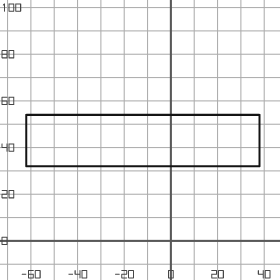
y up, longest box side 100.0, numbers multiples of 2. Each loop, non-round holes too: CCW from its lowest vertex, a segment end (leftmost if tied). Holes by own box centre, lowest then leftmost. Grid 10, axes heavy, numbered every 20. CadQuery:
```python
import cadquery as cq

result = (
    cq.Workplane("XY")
    .moveTo(-62.0, 32.0)
    .lineTo(38.0, 32.0)
    .lineTo(38.0, 54.0)
    .lineTo(-62.0, 54.0)
    .close()
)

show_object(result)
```